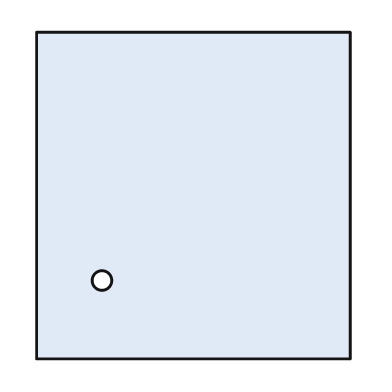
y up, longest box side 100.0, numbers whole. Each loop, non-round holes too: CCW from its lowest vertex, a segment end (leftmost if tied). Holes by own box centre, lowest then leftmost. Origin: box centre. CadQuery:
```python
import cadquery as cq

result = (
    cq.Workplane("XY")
    .moveTo(-48.0, -50.0)
    .lineTo(48.0, -50.0)
    .lineTo(48.0, 50.0)
    .lineTo(-48.0, 50.0)
    .close()
    .moveTo(-28.0, -26.0)
    .circle(3.0)
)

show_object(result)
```